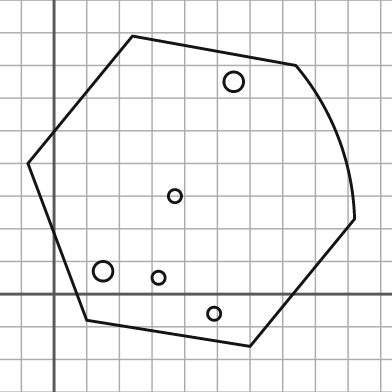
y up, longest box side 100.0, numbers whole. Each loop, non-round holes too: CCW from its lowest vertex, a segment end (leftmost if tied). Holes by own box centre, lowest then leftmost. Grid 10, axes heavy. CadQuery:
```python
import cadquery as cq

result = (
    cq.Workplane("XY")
    .moveTo(60.0, -16.0)
    .lineTo(92.0, 23.0)
    .threePointArc((87.0, 48.0), (74.0, 70.0))
    .lineTo(24.0, 79.0)
    .lineTo(-8.0, 40.0)
    .lineTo(10.0, -8.0)
    .close()
    .moveTo(49.0, -6.0)
    .circle(2.0)
    .moveTo(32.0, 5.0)
    .circle(2.0)
    .moveTo(15.0, 7.0)
    .circle(3.0)
    .moveTo(37.0, 30.0)
    .circle(2.0)
    .moveTo(55.0, 65.0)
    .circle(3.0)
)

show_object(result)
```